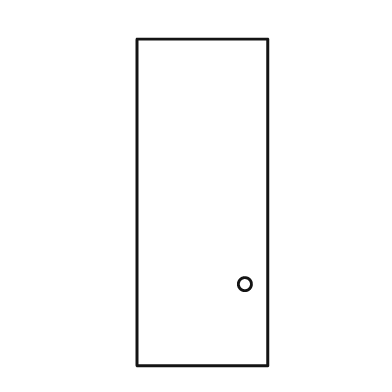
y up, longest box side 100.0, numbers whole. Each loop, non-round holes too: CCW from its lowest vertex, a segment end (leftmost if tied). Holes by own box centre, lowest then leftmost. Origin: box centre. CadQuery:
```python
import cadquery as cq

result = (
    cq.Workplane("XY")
    .moveTo(-20.0, -50.0)
    .lineTo(20.0, -50.0)
    .lineTo(20.0, 50.0)
    .lineTo(-20.0, 50.0)
    .close()
    .moveTo(13.0, -25.0)
    .circle(2.0)
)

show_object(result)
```